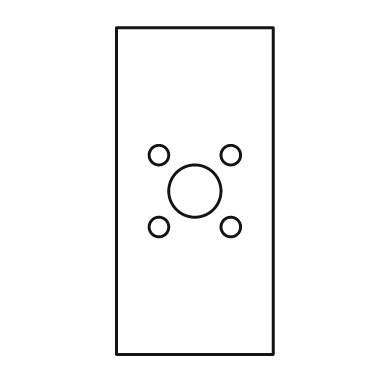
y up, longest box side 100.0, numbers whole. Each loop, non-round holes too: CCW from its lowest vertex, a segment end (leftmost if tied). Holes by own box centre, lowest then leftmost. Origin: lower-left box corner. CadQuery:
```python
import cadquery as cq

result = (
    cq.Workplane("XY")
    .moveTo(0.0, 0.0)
    .lineTo(48.0, 0.0)
    .lineTo(48.0, 100.0)
    .lineTo(0.0, 100.0)
    .close()
    .moveTo(13.0, 39.0)
    .circle(3.0)
    .moveTo(35.0, 39.0)
    .circle(3.0)
    .moveTo(24.0, 50.0)
    .circle(8.0)
    .moveTo(13.0, 61.0)
    .circle(3.0)
    .moveTo(35.0, 61.0)
    .circle(3.0)
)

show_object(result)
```